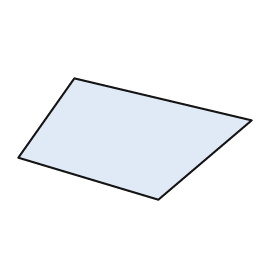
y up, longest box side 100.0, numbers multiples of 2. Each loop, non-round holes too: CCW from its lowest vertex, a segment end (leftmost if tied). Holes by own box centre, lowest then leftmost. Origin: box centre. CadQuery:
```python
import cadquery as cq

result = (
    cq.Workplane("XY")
    .moveTo(10.0, -26.0)
    .lineTo(50.0, 8.0)
    .lineTo(-26.0, 26.0)
    .lineTo(-50.0, -8.0)
    .close()
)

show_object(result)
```